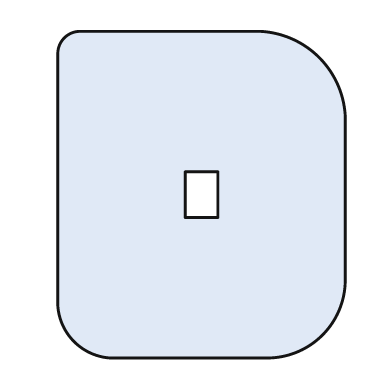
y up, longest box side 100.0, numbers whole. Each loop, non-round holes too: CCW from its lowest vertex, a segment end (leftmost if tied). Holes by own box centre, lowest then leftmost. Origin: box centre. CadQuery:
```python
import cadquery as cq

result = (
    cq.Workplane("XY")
    .moveTo(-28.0, -50.0)
    .lineTo(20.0, -50.0)
    .threePointArc((37.0, -43.0), (44.0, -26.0))
    .lineTo(44.0, 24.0)
    .threePointArc((36.0, 42.0), (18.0, 50.0))
    .lineTo(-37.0, 50.0)
    .threePointArc((-42.0, 48.0), (-44.0, 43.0))
    .lineTo(-44.0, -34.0)
    .threePointArc((-39.0, -45.0), (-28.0, -50.0))
    .close()
    .moveTo(-5.0, -7.0)
    .lineTo(5.0, -7.0)
    .lineTo(5.0, 7.0)
    .lineTo(-5.0, 7.0)
    .close()
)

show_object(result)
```